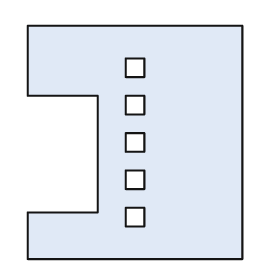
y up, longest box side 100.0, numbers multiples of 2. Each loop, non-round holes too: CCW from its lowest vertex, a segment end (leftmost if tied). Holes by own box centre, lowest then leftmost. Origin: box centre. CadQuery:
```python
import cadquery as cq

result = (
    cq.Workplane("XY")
    .moveTo(-46.0, -50.0)
    .lineTo(46.0, -50.0)
    .lineTo(46.0, 50.0)
    .lineTo(-46.0, 50.0)
    .lineTo(-46.0, 20.0)
    .lineTo(-16.0, 20.0)
    .lineTo(-16.0, -30.0)
    .lineTo(-46.0, -30.0)
    .close()
    .moveTo(-4.0, -36.0)
    .lineTo(4.0, -36.0)
    .lineTo(4.0, -28.0)
    .lineTo(-4.0, -28.0)
    .close()
    .moveTo(-4.0, -20.0)
    .lineTo(4.0, -20.0)
    .lineTo(4.0, -12.0)
    .lineTo(-4.0, -12.0)
    .close()
    .moveTo(-4.0, -4.0)
    .lineTo(4.0, -4.0)
    .lineTo(4.0, 4.0)
    .lineTo(-4.0, 4.0)
    .close()
    .moveTo(-4.0, 12.0)
    .lineTo(4.0, 12.0)
    .lineTo(4.0, 20.0)
    .lineTo(-4.0, 20.0)
    .close()
    .moveTo(-4.0, 28.0)
    .lineTo(4.0, 28.0)
    .lineTo(4.0, 36.0)
    .lineTo(-4.0, 36.0)
    .close()
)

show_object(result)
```